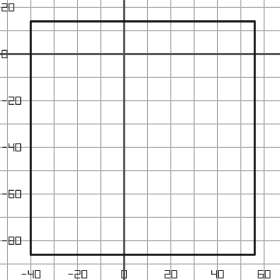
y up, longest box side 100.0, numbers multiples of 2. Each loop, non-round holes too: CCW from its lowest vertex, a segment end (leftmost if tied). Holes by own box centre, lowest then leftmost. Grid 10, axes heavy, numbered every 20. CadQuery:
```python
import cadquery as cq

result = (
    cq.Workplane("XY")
    .moveTo(-40.0, -86.0)
    .lineTo(56.0, -86.0)
    .lineTo(56.0, 14.0)
    .lineTo(-40.0, 14.0)
    .close()
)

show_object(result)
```